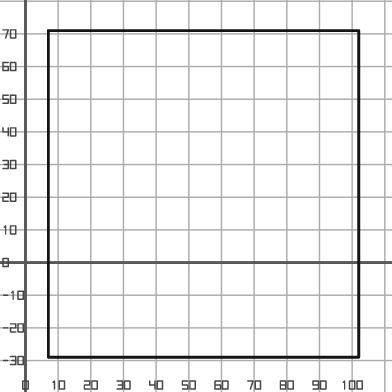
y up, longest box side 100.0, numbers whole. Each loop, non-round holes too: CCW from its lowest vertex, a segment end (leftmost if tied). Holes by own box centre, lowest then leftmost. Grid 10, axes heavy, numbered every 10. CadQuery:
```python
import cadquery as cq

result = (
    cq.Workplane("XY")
    .moveTo(7.0, -29.0)
    .lineTo(102.0, -29.0)
    .lineTo(102.0, 71.0)
    .lineTo(7.0, 71.0)
    .close()
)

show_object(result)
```